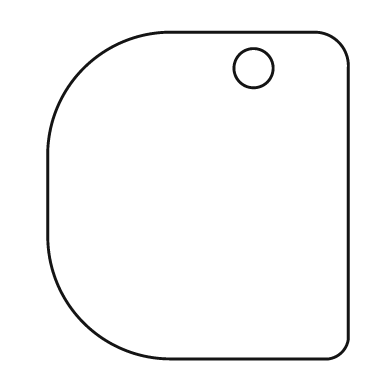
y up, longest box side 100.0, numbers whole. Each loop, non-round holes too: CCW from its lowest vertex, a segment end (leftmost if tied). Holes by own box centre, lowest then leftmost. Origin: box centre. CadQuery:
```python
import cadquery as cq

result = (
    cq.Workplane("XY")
    .moveTo(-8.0, -50.0)
    .lineTo(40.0, -50.0)
    .threePointArc((44.0, -48.0), (46.0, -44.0))
    .lineTo(46.0, 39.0)
    .threePointArc((43.0, 47.0), (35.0, 50.0))
    .lineTo(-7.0, 50.0)
    .threePointArc((-35.0, 39.0), (-46.0, 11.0))
    .lineTo(-46.0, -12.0)
    .threePointArc((-35.0, -39.0), (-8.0, -50.0))
    .close()
    .moveTo(17.0, 39.0)
    .circle(6.0)
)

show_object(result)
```